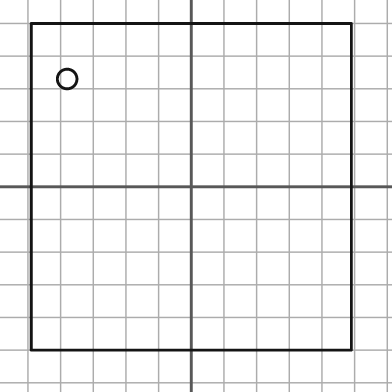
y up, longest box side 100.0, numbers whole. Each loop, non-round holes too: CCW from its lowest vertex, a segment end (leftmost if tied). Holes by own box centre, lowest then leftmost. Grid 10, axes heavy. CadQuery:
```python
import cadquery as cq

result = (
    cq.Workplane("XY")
    .moveTo(-49.0, -50.0)
    .lineTo(49.0, -50.0)
    .lineTo(49.0, 50.0)
    .lineTo(-49.0, 50.0)
    .close()
    .moveTo(-38.0, 33.0)
    .circle(3.0)
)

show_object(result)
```